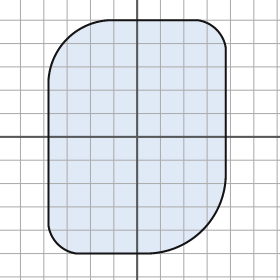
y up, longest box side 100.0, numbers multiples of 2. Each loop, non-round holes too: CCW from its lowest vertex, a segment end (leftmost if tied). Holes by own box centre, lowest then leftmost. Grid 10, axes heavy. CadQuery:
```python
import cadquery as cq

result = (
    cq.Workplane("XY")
    .moveTo(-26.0, -50.0)
    .lineTo(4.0, -50.0)
    .threePointArc((28.0, -40.0), (38.0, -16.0))
    .lineTo(38.0, 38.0)
    .threePointArc((34.0, 46.0), (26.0, 50.0))
    .lineTo(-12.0, 50.0)
    .threePointArc((-30.0, 42.0), (-38.0, 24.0))
    .lineTo(-38.0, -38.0)
    .threePointArc((-34.0, -46.0), (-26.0, -50.0))
    .close()
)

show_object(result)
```